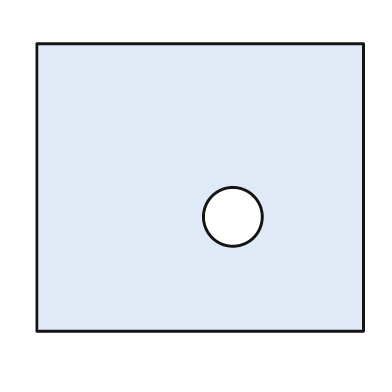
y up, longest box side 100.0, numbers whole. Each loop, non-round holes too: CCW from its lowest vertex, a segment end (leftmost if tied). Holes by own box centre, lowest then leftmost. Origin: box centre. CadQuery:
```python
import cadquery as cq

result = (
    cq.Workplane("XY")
    .moveTo(-50.0, -44.0)
    .lineTo(50.0, -44.0)
    .lineTo(50.0, 44.0)
    .lineTo(-50.0, 44.0)
    .close()
    .moveTo(10.0, -9.0)
    .circle(9.0)
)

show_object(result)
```